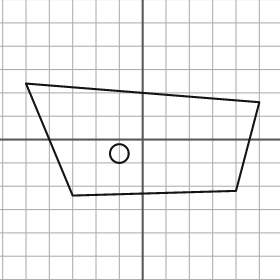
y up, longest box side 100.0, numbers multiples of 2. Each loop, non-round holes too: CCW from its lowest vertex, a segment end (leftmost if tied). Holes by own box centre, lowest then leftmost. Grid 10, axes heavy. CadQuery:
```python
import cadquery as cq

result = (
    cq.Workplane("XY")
    .moveTo(-30.0, -24.0)
    .lineTo(40.0, -22.0)
    .lineTo(50.0, 16.0)
    .lineTo(-50.0, 24.0)
    .close()
    .moveTo(-10.0, -6.0)
    .circle(4.0)
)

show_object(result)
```